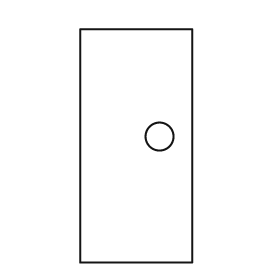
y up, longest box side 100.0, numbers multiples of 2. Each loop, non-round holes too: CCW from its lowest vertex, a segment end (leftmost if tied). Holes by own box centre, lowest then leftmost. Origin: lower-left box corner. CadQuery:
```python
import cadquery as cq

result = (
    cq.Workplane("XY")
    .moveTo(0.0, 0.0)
    .lineTo(48.0, 0.0)
    .lineTo(48.0, 100.0)
    .lineTo(0.0, 100.0)
    .close()
    .moveTo(34.0, 54.0)
    .circle(6.0)
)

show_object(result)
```